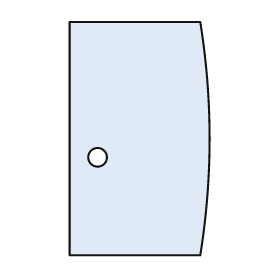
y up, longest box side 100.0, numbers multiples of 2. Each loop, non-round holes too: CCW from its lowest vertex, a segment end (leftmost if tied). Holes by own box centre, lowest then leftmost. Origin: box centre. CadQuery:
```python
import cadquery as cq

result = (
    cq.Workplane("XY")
    .moveTo(-30.0, -50.0)
    .lineTo(26.0, -50.0)
    .threePointArc((30.0, 0.0), (26.0, 50.0))
    .lineTo(-30.0, 50.0)
    .close()
    .moveTo(-18.0, -8.0)
    .circle(4.0)
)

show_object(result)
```